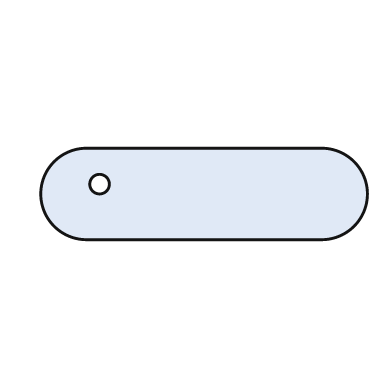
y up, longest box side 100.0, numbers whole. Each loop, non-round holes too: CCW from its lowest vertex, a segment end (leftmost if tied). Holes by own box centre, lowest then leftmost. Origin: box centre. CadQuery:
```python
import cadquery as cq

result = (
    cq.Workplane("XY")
    .moveTo(-36.0, -14.0)
    .lineTo(36.0, -14.0)
    .threePointArc((50.0, 0.0), (36.0, 14.0))
    .lineTo(-36.0, 14.0)
    .threePointArc((-50.0, 0.0), (-36.0, -14.0))
    .close()
    .moveTo(-32.0, 3.0)
    .circle(3.0)
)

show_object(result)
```